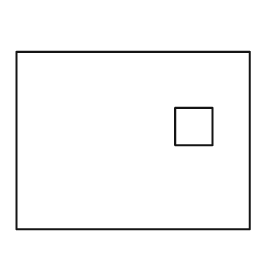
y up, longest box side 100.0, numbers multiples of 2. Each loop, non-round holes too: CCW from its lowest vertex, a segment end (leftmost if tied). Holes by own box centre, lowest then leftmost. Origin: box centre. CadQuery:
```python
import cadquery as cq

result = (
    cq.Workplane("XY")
    .moveTo(-50.0, -38.0)
    .lineTo(50.0, -38.0)
    .lineTo(50.0, 38.0)
    .lineTo(-50.0, 38.0)
    .close()
    .moveTo(18.0, -2.0)
    .lineTo(34.0, -2.0)
    .lineTo(34.0, 14.0)
    .lineTo(18.0, 14.0)
    .close()
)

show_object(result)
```